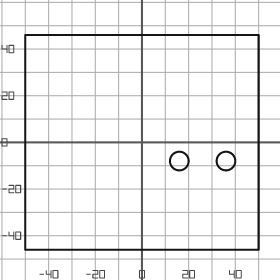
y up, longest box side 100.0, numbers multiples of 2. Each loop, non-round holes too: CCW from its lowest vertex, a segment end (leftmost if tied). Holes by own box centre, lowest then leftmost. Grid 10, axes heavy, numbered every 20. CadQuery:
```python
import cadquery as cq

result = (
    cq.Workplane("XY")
    .moveTo(-50.0, -46.0)
    .lineTo(50.0, -46.0)
    .lineTo(50.0, 46.0)
    .lineTo(-50.0, 46.0)
    .close()
    .moveTo(16.0, -8.0)
    .circle(4.0)
    .moveTo(36.0, -8.0)
    .circle(4.0)
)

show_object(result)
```